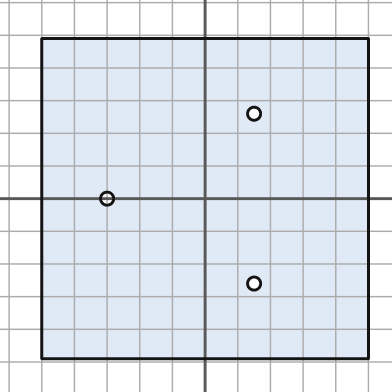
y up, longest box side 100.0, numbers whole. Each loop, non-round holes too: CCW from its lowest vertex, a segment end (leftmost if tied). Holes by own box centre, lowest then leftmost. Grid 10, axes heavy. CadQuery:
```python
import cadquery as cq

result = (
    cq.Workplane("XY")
    .moveTo(-50.0, -49.0)
    .lineTo(50.0, -49.0)
    .lineTo(50.0, 49.0)
    .lineTo(-50.0, 49.0)
    .close()
    .moveTo(15.0, -26.0)
    .circle(2.0)
    .moveTo(-30.0, 0.0)
    .circle(2.0)
    .moveTo(15.0, 26.0)
    .circle(2.0)
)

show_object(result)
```